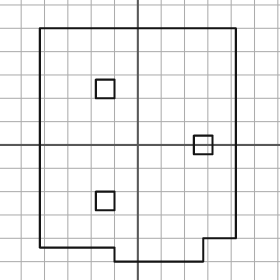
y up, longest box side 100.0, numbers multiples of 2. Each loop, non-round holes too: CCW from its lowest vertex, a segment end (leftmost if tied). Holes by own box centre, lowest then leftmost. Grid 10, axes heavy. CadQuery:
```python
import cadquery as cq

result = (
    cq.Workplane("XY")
    .moveTo(-10.0, -50.0)
    .lineTo(28.0, -50.0)
    .lineTo(28.0, -40.0)
    .lineTo(42.0, -40.0)
    .lineTo(42.0, 50.0)
    .lineTo(-42.0, 50.0)
    .lineTo(-42.0, -44.0)
    .lineTo(-10.0, -44.0)
    .close()
    .moveTo(-18.0, -28.0)
    .lineTo(-10.0, -28.0)
    .lineTo(-10.0, -20.0)
    .lineTo(-18.0, -20.0)
    .close()
    .moveTo(24.0, -4.0)
    .lineTo(32.0, -4.0)
    .lineTo(32.0, 4.0)
    .lineTo(24.0, 4.0)
    .close()
    .moveTo(-18.0, 20.0)
    .lineTo(-10.0, 20.0)
    .lineTo(-10.0, 28.0)
    .lineTo(-18.0, 28.0)
    .close()
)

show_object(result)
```